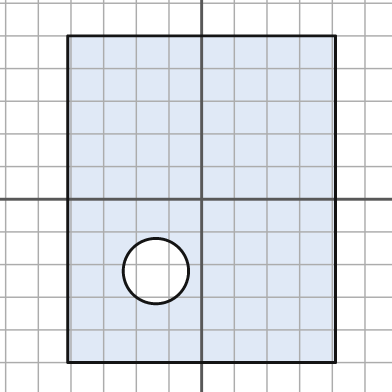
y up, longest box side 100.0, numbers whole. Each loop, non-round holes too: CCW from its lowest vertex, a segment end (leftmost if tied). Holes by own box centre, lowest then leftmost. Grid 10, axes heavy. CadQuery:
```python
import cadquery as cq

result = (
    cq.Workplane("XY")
    .moveTo(-41.0, -50.0)
    .lineTo(41.0, -50.0)
    .lineTo(41.0, 50.0)
    .lineTo(-41.0, 50.0)
    .close()
    .moveTo(-14.0, -22.0)
    .circle(10.0)
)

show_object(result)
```